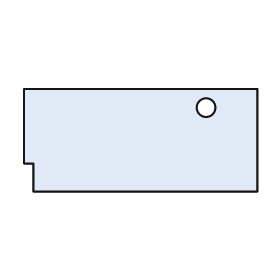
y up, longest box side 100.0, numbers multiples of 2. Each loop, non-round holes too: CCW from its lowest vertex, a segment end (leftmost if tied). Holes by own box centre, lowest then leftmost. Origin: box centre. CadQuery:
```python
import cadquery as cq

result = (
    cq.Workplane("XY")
    .moveTo(-46.0, -22.0)
    .lineTo(50.0, -22.0)
    .lineTo(50.0, 22.0)
    .lineTo(-50.0, 22.0)
    .lineTo(-50.0, -10.0)
    .lineTo(-46.0, -10.0)
    .close()
    .moveTo(28.0, 14.0)
    .circle(4.0)
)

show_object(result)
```